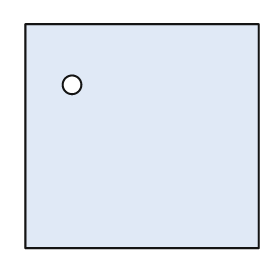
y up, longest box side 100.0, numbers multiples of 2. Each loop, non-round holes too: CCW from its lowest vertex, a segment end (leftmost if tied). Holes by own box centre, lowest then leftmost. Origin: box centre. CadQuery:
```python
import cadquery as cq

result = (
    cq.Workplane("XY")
    .moveTo(-50.0, -48.0)
    .lineTo(50.0, -48.0)
    .lineTo(50.0, 48.0)
    .lineTo(-50.0, 48.0)
    .close()
    .moveTo(-30.0, 22.0)
    .circle(4.0)
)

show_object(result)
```